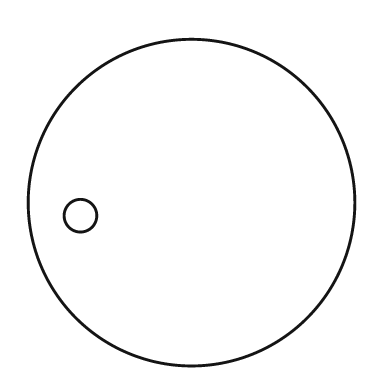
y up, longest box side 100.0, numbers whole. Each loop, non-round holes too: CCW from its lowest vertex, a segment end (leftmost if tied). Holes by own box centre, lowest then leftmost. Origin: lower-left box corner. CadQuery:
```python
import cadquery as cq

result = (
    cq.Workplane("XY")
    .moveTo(50.0, 50.0)
    .circle(50.0)
    .moveTo(16.0, 46.0)
    .circle(5.0)
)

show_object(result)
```